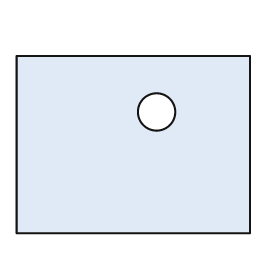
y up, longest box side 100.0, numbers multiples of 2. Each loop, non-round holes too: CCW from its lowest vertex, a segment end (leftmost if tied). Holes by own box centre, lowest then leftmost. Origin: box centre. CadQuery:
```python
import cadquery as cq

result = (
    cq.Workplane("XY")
    .moveTo(-50.0, -38.0)
    .lineTo(50.0, -38.0)
    .lineTo(50.0, 38.0)
    .lineTo(-50.0, 38.0)
    .close()
    .moveTo(10.0, 14.0)
    .circle(8.0)
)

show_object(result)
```